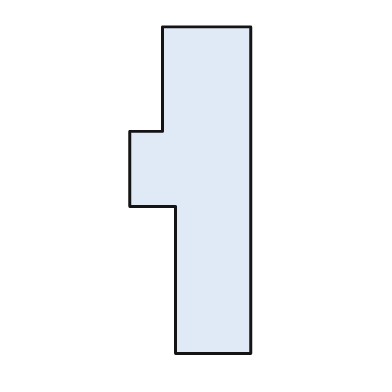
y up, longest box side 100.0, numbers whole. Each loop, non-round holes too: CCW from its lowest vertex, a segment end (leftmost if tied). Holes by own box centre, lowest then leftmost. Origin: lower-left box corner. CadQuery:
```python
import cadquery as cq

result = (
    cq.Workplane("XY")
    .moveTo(14.0, 0.0)
    .lineTo(37.0, 0.0)
    .lineTo(37.0, 100.0)
    .lineTo(10.0, 100.0)
    .lineTo(10.0, 68.0)
    .lineTo(0.0, 68.0)
    .lineTo(0.0, 45.0)
    .lineTo(14.0, 45.0)
    .close()
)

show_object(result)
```